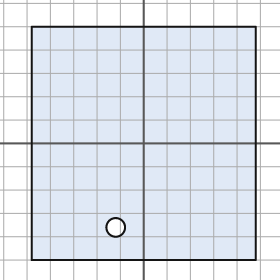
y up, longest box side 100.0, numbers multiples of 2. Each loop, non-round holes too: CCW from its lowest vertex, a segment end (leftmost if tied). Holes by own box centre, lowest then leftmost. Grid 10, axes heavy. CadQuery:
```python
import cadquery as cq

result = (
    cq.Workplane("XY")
    .moveTo(-48.0, -50.0)
    .lineTo(48.0, -50.0)
    .lineTo(48.0, 50.0)
    .lineTo(-48.0, 50.0)
    .close()
    .moveTo(-12.0, -36.0)
    .circle(4.0)
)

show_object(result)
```